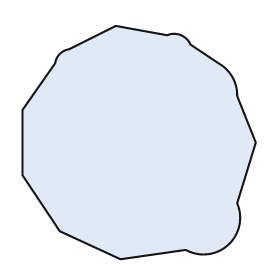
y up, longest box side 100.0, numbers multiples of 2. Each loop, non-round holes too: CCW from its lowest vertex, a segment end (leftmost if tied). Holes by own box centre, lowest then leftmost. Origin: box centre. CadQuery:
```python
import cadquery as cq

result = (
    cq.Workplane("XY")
    .moveTo(-8.0, -50.0)
    .lineTo(20.0, -46.0)
    .threePointArc((38.0, -44.0), (42.0, -26.0))
    .lineTo(50.0, 0.0)
    .lineTo(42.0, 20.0)
    .threePointArc((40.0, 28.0), (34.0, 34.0))
    .lineTo(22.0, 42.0)
    .threePointArc((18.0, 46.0), (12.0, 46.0))
    .lineTo(-10.0, 50.0)
    .lineTo(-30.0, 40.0)
    .threePointArc((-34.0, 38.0), (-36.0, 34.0))
    .lineTo(-50.0, 14.0)
    .lineTo(-50.0, -14.0)
    .lineTo(-34.0, -38.0)
    .close()
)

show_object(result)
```